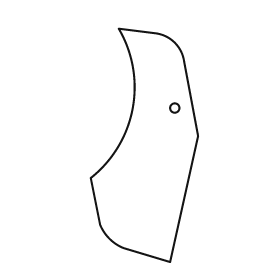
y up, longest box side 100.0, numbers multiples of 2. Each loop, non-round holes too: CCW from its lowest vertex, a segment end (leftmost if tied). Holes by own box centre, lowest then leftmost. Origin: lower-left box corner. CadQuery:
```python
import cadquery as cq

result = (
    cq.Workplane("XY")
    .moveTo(34.0, 0.0)
    .lineTo(46.0, 54.0)
    .lineTo(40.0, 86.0)
    .threePointArc((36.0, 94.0), (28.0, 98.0))
    .lineTo(12.0, 100.0)
    .threePointArc((18.0, 66.0), (0.0, 36.0))
    .lineTo(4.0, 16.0)
    .threePointArc((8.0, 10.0), (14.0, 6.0))
    .close()
    .moveTo(36.0, 66.0)
    .circle(2.0)
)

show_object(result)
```